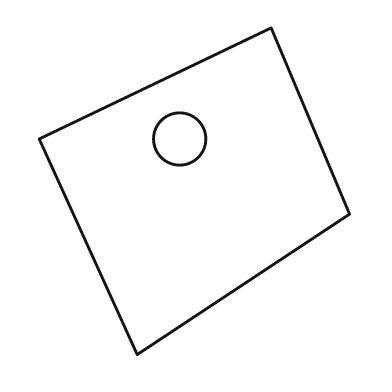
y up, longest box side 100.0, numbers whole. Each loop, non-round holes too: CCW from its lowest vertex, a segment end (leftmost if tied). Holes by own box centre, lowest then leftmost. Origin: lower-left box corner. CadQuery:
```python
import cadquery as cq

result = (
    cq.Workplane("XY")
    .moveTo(30.0, 0.0)
    .lineTo(95.0, 43.0)
    .lineTo(71.0, 100.0)
    .lineTo(0.0, 66.0)
    .close()
    .moveTo(43.0, 66.0)
    .circle(8.0)
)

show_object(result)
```